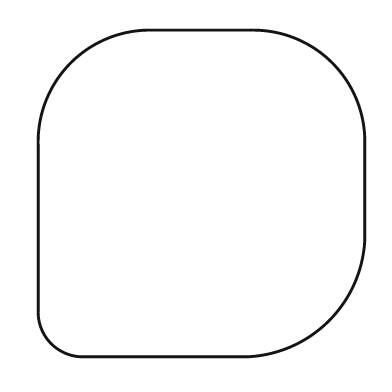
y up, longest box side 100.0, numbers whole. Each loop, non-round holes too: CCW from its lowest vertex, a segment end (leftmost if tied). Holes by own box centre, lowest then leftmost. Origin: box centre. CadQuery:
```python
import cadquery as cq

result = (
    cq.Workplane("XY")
    .moveTo(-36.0, -50.0)
    .lineTo(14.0, -50.0)
    .threePointArc((39.0, -39.0), (50.0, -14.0))
    .lineTo(50.0, 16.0)
    .threePointArc((40.0, 40.0), (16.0, 50.0))
    .lineTo(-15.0, 50.0)
    .threePointArc((-40.0, 40.0), (-50.0, 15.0))
    .lineTo(-50.0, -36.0)
    .threePointArc((-46.0, -46.0), (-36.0, -50.0))
    .close()
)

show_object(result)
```